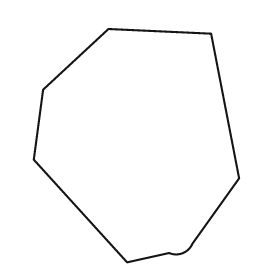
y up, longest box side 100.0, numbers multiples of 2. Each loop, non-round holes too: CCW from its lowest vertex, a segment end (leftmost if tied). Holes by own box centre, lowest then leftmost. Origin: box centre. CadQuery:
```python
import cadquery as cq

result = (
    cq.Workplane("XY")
    .moveTo(-4.0, -50.0)
    .lineTo(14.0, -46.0)
    .threePointArc((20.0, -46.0), (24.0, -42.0))
    .lineTo(44.0, -14.0)
    .lineTo(32.0, 48.0)
    .lineTo(-12.0, 50.0)
    .lineTo(-40.0, 24.0)
    .lineTo(-44.0, -6.0)
    .close()
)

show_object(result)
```